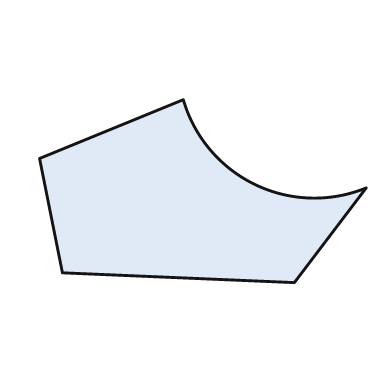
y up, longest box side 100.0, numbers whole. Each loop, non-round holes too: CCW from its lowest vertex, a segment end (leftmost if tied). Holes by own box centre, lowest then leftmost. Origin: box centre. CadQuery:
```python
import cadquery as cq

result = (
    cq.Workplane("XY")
    .moveTo(28.0, -28.0)
    .lineTo(50.0, 1.0)
    .threePointArc((16.0, 2.0), (-6.0, 28.0))
    .lineTo(-50.0, 10.0)
    .lineTo(-43.0, -25.0)
    .close()
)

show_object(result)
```